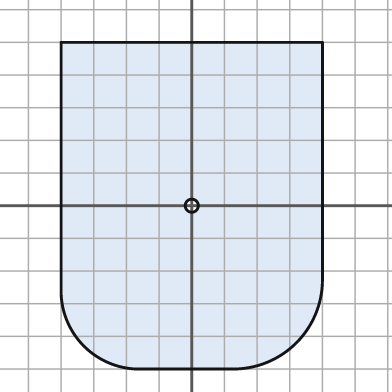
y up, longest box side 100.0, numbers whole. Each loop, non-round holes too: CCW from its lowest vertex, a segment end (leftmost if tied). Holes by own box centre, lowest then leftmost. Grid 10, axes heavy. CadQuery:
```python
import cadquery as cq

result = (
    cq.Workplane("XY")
    .moveTo(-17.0, -50.0)
    .lineTo(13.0, -50.0)
    .threePointArc((32.0, -42.0), (40.0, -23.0))
    .lineTo(40.0, 50.0)
    .lineTo(-40.0, 50.0)
    .lineTo(-40.0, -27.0)
    .threePointArc((-33.0, -43.0), (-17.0, -50.0))
    .close()
    .moveTo(0.0, 0.0)
    .circle(2.0)
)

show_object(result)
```